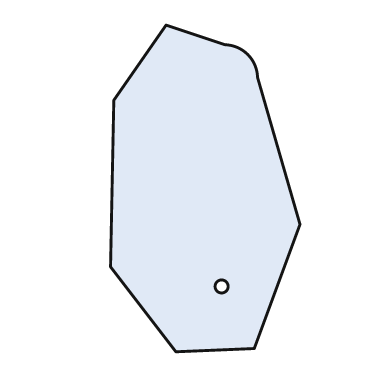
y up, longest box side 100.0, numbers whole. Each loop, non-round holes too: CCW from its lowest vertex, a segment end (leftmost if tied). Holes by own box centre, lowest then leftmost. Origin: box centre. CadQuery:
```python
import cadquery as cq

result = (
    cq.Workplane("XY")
    .moveTo(-9.0, -50.0)
    .lineTo(15.0, -49.0)
    .lineTo(29.0, -11.0)
    .lineTo(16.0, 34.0)
    .threePointArc((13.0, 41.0), (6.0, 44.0))
    .lineTo(-12.0, 50.0)
    .lineTo(-28.0, 27.0)
    .lineTo(-29.0, -24.0)
    .close()
    .moveTo(5.0, -30.0)
    .circle(2.0)
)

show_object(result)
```